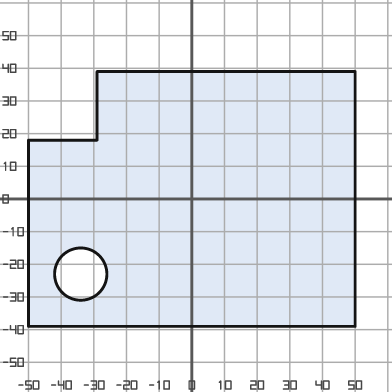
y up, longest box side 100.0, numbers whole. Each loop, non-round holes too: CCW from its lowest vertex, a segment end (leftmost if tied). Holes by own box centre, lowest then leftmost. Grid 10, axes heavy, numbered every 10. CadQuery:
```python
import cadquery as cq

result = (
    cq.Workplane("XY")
    .moveTo(-50.0, -39.0)
    .lineTo(50.0, -39.0)
    .lineTo(50.0, 39.0)
    .lineTo(-29.0, 39.0)
    .lineTo(-29.0, 18.0)
    .lineTo(-50.0, 18.0)
    .close()
    .moveTo(-34.0, -23.0)
    .circle(8.0)
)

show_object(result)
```